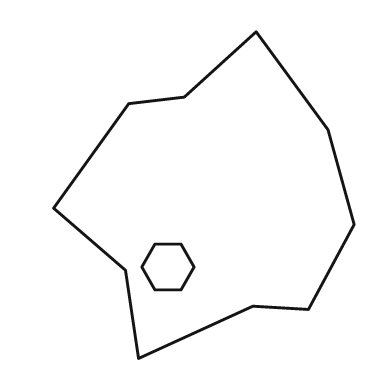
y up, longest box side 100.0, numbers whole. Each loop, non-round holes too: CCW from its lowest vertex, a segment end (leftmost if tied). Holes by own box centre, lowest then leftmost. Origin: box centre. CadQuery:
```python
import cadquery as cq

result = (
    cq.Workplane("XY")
    .moveTo(-20.0, -50.0)
    .lineTo(15.0, -34.0)
    .lineTo(32.0, -35.0)
    .lineTo(46.0, -9.0)
    .lineTo(38.0, 20.0)
    .lineTo(16.0, 50.0)
    .lineTo(-6.0, 30.0)
    .lineTo(-23.0, 28.0)
    .lineTo(-46.0, -4.0)
    .lineTo(-24.0, -23.0)
    .close()
    .moveTo(-15.0, -29.0)
    .lineTo(-7.0, -29.0)
    .lineTo(-3.0, -22.0)
    .lineTo(-7.0, -15.0)
    .lineTo(-15.0, -15.0)
    .lineTo(-19.0, -22.0)
    .close()
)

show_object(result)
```